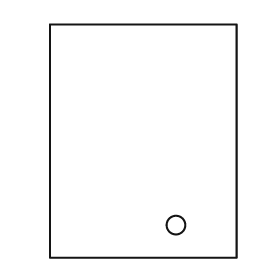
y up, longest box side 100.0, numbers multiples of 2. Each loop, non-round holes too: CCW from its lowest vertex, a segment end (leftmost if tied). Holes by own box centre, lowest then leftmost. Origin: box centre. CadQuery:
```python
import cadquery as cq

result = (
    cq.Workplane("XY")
    .moveTo(-40.0, -50.0)
    .lineTo(40.0, -50.0)
    .lineTo(40.0, 50.0)
    .lineTo(-40.0, 50.0)
    .close()
    .moveTo(14.0, -36.0)
    .circle(4.0)
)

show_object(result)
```